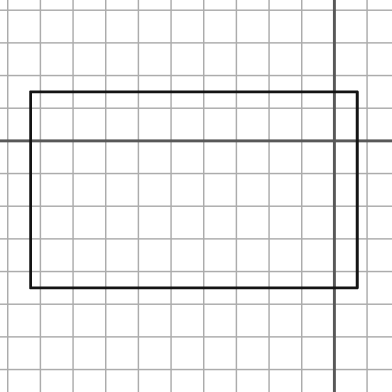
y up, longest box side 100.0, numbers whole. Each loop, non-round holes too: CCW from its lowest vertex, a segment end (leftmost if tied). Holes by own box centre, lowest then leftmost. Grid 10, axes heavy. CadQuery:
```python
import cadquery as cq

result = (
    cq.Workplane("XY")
    .moveTo(-93.0, -45.0)
    .lineTo(7.0, -45.0)
    .lineTo(7.0, 15.0)
    .lineTo(-93.0, 15.0)
    .close()
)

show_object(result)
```